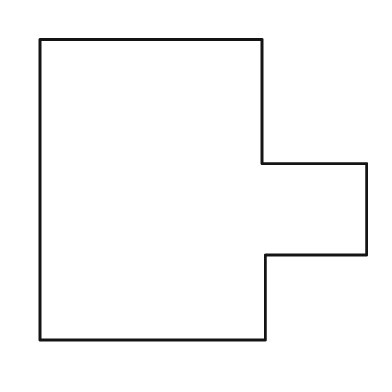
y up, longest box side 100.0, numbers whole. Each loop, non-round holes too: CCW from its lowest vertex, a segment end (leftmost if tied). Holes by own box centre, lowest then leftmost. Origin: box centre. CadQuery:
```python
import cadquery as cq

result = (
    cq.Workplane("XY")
    .moveTo(-50.0, -46.0)
    .lineTo(19.0, -46.0)
    .lineTo(19.0, -20.0)
    .lineTo(50.0, -20.0)
    .lineTo(50.0, 8.0)
    .lineTo(18.0, 8.0)
    .lineTo(18.0, 46.0)
    .lineTo(-50.0, 46.0)
    .close()
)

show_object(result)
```